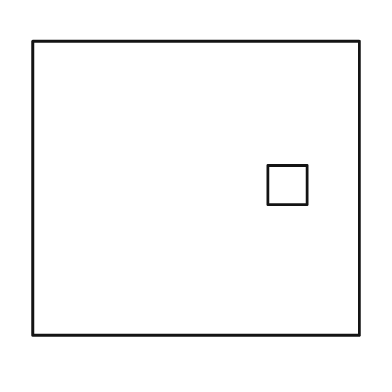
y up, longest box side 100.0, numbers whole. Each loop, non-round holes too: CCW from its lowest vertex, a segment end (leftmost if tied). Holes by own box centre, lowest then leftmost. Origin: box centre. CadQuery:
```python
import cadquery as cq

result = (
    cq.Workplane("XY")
    .moveTo(-50.0, -45.0)
    .lineTo(50.0, -45.0)
    .lineTo(50.0, 45.0)
    .lineTo(-50.0, 45.0)
    .close()
    .moveTo(22.0, -5.0)
    .lineTo(34.0, -5.0)
    .lineTo(34.0, 7.0)
    .lineTo(22.0, 7.0)
    .close()
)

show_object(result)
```